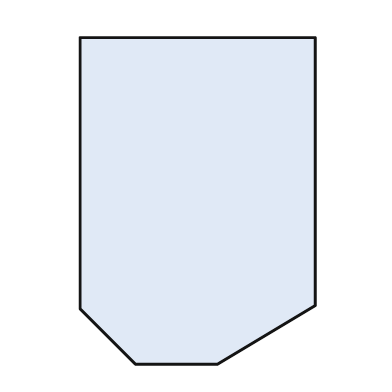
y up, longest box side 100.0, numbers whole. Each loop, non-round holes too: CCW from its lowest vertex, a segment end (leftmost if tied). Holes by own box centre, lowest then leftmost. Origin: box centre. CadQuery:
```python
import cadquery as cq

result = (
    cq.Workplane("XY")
    .moveTo(-19.0, -50.0)
    .lineTo(6.0, -50.0)
    .lineTo(36.0, -32.0)
    .lineTo(36.0, 50.0)
    .lineTo(-36.0, 50.0)
    .lineTo(-36.0, -33.0)
    .close()
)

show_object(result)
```